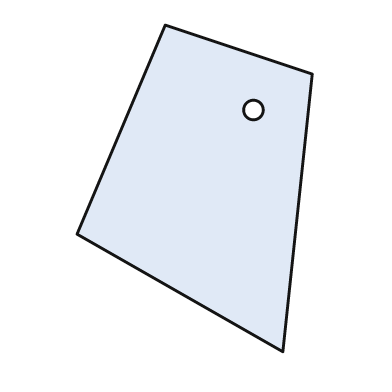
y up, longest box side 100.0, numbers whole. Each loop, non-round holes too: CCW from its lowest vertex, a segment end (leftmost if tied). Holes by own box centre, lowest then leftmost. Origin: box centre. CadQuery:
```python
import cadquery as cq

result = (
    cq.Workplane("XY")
    .moveTo(27.0, -50.0)
    .lineTo(36.0, 35.0)
    .lineTo(-9.0, 50.0)
    .lineTo(-36.0, -14.0)
    .close()
    .moveTo(18.0, 24.0)
    .circle(3.0)
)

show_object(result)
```